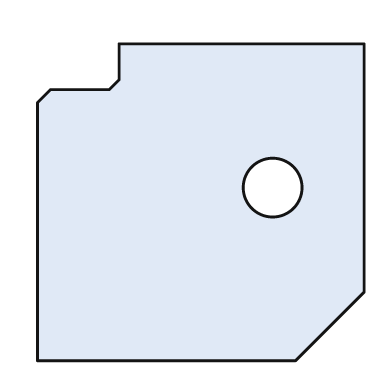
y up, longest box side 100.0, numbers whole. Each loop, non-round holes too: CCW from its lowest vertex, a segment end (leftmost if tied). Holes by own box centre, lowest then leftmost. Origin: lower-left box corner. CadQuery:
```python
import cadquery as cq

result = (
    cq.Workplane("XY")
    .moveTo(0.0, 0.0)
    .lineTo(79.0, 0.0)
    .lineTo(100.0, 21.0)
    .lineTo(100.0, 97.0)
    .lineTo(25.0, 97.0)
    .lineTo(25.0, 86.0)
    .lineTo(22.0, 83.0)
    .lineTo(4.0, 83.0)
    .lineTo(0.0, 79.0)
    .close()
    .moveTo(72.0, 53.0)
    .circle(9.0)
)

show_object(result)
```